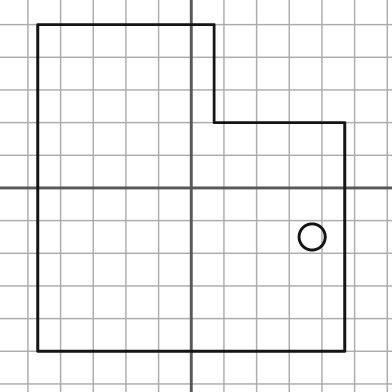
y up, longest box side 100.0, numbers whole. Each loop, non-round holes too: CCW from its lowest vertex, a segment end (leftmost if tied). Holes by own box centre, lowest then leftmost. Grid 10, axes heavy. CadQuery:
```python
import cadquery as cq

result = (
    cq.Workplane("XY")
    .moveTo(-47.0, -50.0)
    .lineTo(47.0, -50.0)
    .lineTo(47.0, 20.0)
    .lineTo(7.0, 20.0)
    .lineTo(7.0, 50.0)
    .lineTo(-47.0, 50.0)
    .close()
    .moveTo(37.0, -15.0)
    .circle(4.0)
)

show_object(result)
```